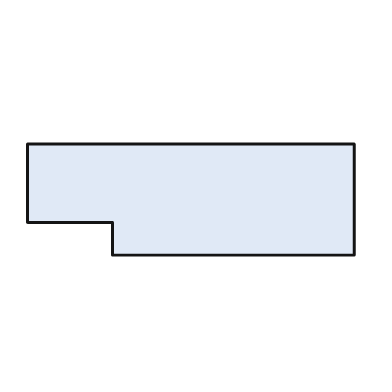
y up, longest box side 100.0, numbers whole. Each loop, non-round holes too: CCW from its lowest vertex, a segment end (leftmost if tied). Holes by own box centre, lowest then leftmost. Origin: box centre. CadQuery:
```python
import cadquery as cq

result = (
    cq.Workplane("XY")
    .moveTo(-24.0, -17.0)
    .lineTo(50.0, -17.0)
    .lineTo(50.0, 17.0)
    .lineTo(-50.0, 17.0)
    .lineTo(-50.0, -7.0)
    .lineTo(-24.0, -7.0)
    .close()
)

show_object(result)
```